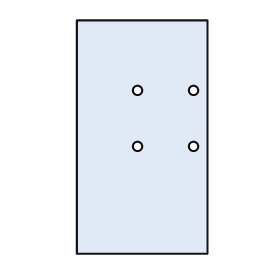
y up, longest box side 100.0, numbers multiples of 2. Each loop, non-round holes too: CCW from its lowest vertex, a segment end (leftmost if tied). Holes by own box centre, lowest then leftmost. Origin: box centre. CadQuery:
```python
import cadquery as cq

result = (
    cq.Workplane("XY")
    .moveTo(-28.0, -50.0)
    .lineTo(28.0, -50.0)
    .lineTo(28.0, 50.0)
    .lineTo(-28.0, 50.0)
    .close()
    .moveTo(-2.0, -4.0)
    .circle(2.0)
    .moveTo(22.0, -4.0)
    .circle(2.0)
    .moveTo(-2.0, 20.0)
    .circle(2.0)
    .moveTo(22.0, 20.0)
    .circle(2.0)
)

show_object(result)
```